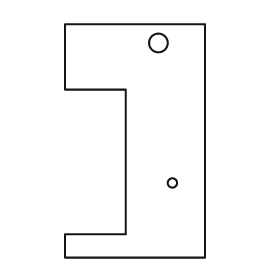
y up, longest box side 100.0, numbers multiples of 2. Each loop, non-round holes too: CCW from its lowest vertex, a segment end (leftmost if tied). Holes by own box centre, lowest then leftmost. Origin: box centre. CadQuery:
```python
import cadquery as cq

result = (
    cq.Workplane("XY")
    .moveTo(-30.0, -50.0)
    .lineTo(30.0, -50.0)
    .lineTo(30.0, 50.0)
    .lineTo(-30.0, 50.0)
    .lineTo(-30.0, 22.0)
    .lineTo(-4.0, 22.0)
    .lineTo(-4.0, -40.0)
    .lineTo(-30.0, -40.0)
    .close()
    .moveTo(16.0, -18.0)
    .circle(2.0)
    .moveTo(10.0, 42.0)
    .circle(4.0)
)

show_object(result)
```